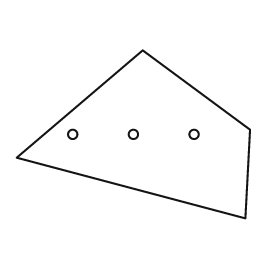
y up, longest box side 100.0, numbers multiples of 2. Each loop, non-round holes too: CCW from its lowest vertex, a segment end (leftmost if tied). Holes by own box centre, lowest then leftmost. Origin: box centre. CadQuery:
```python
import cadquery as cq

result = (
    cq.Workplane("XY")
    .moveTo(48.0, -36.0)
    .lineTo(50.0, 2.0)
    .lineTo(4.0, 36.0)
    .lineTo(-50.0, -10.0)
    .close()
    .moveTo(-26.0, 0.0)
    .circle(2.0)
    .moveTo(0.0, 0.0)
    .circle(2.0)
    .moveTo(26.0, 0.0)
    .circle(2.0)
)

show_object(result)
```